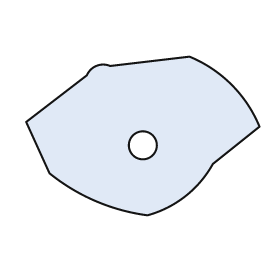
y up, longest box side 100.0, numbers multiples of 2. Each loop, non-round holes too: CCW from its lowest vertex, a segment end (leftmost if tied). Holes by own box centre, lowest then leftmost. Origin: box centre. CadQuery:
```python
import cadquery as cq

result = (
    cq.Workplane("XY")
    .moveTo(2.0, -34.0)
    .threePointArc((18.0, -26.0), (30.0, -12.0))
    .lineTo(50.0, 4.0)
    .threePointArc((38.0, 22.0), (20.0, 34.0))
    .lineTo(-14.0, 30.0)
    .threePointArc((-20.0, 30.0), (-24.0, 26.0))
    .lineTo(-50.0, 6.0)
    .lineTo(-40.0, -16.0)
    .threePointArc((-20.0, -28.0), (2.0, -34.0))
    .close()
    .moveTo(0.0, -4.0)
    .circle(6.0)
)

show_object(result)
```